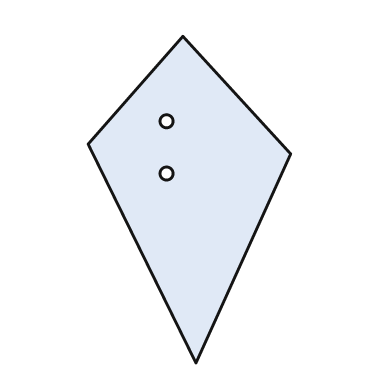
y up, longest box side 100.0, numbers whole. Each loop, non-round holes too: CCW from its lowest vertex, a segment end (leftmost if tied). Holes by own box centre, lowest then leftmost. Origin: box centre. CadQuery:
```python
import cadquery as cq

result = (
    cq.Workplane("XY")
    .moveTo(2.0, -50.0)
    .lineTo(31.0, 14.0)
    .lineTo(-2.0, 50.0)
    .lineTo(-31.0, 17.0)
    .close()
    .moveTo(-7.0, 8.0)
    .circle(2.0)
    .moveTo(-7.0, 24.0)
    .circle(2.0)
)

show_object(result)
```